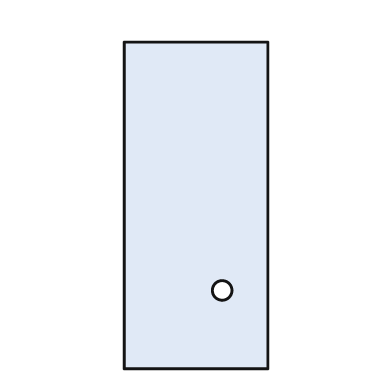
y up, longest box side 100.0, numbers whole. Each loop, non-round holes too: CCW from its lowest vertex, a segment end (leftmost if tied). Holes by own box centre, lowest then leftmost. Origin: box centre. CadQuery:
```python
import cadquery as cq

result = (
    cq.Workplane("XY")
    .moveTo(-22.0, -50.0)
    .lineTo(22.0, -50.0)
    .lineTo(22.0, 50.0)
    .lineTo(-22.0, 50.0)
    .close()
    .moveTo(8.0, -26.0)
    .circle(3.0)
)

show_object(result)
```